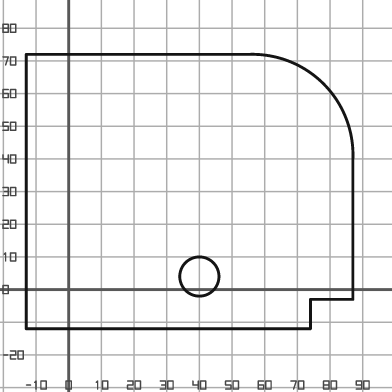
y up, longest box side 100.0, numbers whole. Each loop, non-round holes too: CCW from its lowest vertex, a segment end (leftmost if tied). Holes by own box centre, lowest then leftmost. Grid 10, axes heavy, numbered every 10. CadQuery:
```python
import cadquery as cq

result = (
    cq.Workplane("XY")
    .moveTo(-13.0, -12.0)
    .lineTo(74.0, -12.0)
    .lineTo(74.0, -3.0)
    .lineTo(87.0, -3.0)
    .lineTo(87.0, 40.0)
    .threePointArc((78.0, 63.0), (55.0, 72.0))
    .lineTo(-13.0, 72.0)
    .close()
    .moveTo(40.0, 4.0)
    .circle(6.0)
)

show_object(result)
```